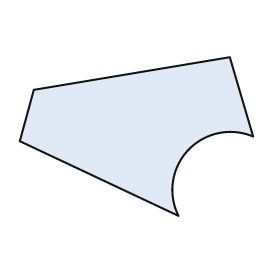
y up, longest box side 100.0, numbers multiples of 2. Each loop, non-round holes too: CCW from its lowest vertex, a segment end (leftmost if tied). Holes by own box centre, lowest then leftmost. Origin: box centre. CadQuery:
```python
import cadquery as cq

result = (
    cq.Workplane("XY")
    .moveTo(18.0, -34.0)
    .threePointArc((22.0, -6.0), (50.0, 0.0))
    .lineTo(40.0, 34.0)
    .lineTo(-44.0, 20.0)
    .lineTo(-50.0, -2.0)
    .close()
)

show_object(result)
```